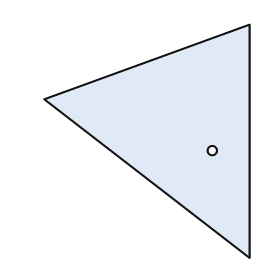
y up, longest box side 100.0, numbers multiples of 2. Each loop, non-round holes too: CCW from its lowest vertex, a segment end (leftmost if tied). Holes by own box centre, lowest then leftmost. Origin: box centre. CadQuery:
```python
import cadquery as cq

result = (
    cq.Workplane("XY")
    .moveTo(44.0, -50.0)
    .lineTo(44.0, 50.0)
    .lineTo(-44.0, 18.0)
    .close()
    .moveTo(28.0, -4.0)
    .circle(2.0)
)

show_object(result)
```